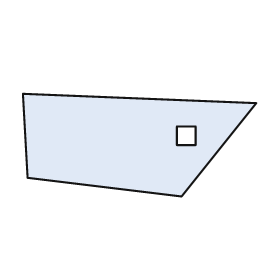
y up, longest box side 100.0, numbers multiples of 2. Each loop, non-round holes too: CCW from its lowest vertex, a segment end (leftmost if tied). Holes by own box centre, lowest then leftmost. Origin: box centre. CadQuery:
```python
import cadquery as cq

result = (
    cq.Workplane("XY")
    .moveTo(18.0, -22.0)
    .lineTo(50.0, 18.0)
    .lineTo(-50.0, 22.0)
    .lineTo(-48.0, -14.0)
    .close()
    .moveTo(16.0, 0.0)
    .lineTo(24.0, 0.0)
    .lineTo(24.0, 8.0)
    .lineTo(16.0, 8.0)
    .close()
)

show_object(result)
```